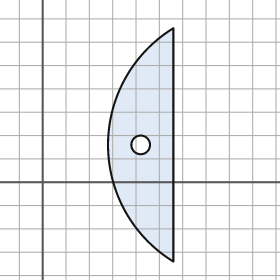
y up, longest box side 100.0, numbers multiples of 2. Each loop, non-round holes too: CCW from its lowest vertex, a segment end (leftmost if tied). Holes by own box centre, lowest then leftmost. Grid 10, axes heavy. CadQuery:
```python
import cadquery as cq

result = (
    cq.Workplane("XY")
    .moveTo(56.0, -34.0)
    .lineTo(56.0, 66.0)
    .threePointArc((28.0, 16.0), (56.0, -34.0))
    .close()
    .moveTo(42.0, 16.0)
    .circle(4.0)
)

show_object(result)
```